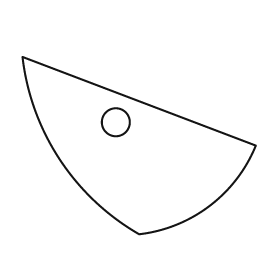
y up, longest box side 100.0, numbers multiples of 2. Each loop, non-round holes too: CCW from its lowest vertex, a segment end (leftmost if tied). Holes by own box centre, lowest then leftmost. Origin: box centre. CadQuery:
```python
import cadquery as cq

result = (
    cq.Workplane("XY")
    .moveTo(0.0, -38.0)
    .threePointArc((30.0, -26.0), (50.0, 0.0))
    .lineTo(-50.0, 38.0)
    .threePointArc((-34.0, -6.0), (0.0, -38.0))
    .close()
    .moveTo(-10.0, 10.0)
    .circle(6.0)
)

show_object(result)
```